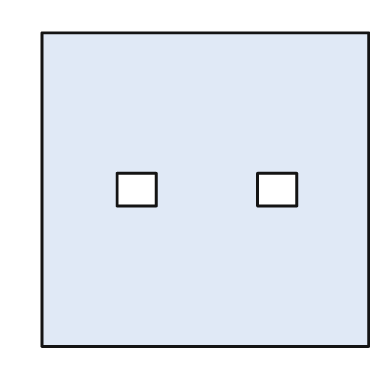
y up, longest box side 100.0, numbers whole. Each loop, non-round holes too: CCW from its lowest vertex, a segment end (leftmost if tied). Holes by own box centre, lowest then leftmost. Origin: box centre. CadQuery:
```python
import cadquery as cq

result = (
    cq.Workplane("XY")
    .moveTo(-50.0, -48.0)
    .lineTo(50.0, -48.0)
    .lineTo(50.0, 48.0)
    .lineTo(-50.0, 48.0)
    .close()
    .moveTo(-27.0, -5.0)
    .lineTo(-15.0, -5.0)
    .lineTo(-15.0, 5.0)
    .lineTo(-27.0, 5.0)
    .close()
    .moveTo(16.0, -5.0)
    .lineTo(28.0, -5.0)
    .lineTo(28.0, 5.0)
    .lineTo(16.0, 5.0)
    .close()
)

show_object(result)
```